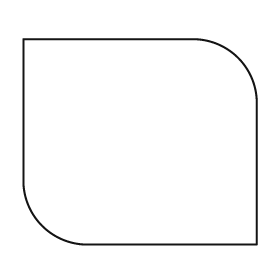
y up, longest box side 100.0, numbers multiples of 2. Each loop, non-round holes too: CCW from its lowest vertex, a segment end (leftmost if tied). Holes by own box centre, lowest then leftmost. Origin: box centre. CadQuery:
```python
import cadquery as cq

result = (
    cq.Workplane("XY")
    .moveTo(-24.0, -44.0)
    .lineTo(50.0, -44.0)
    .lineTo(50.0, 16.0)
    .threePointArc((42.0, 36.0), (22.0, 44.0))
    .lineTo(-50.0, 44.0)
    .lineTo(-50.0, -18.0)
    .threePointArc((-42.0, -36.0), (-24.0, -44.0))
    .close()
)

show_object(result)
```